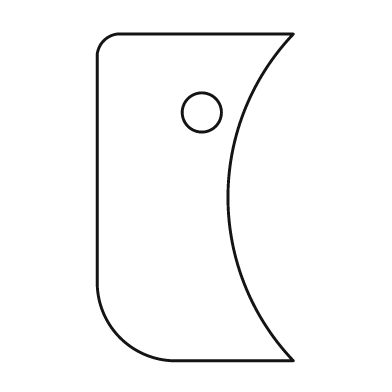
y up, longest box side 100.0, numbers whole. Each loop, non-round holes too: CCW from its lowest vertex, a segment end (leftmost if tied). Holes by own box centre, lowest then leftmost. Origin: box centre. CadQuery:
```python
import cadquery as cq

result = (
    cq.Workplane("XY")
    .moveTo(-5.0, -50.0)
    .lineTo(30.0, -50.0)
    .threePointArc((10.0, 0.0), (30.0, 50.0))
    .lineTo(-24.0, 50.0)
    .threePointArc((-28.0, 48.0), (-30.0, 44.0))
    .lineTo(-30.0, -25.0)
    .threePointArc((-23.0, -43.0), (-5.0, -50.0))
    .close()
    .moveTo(2.0, 26.0)
    .circle(6.0)
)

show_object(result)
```